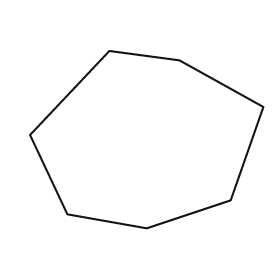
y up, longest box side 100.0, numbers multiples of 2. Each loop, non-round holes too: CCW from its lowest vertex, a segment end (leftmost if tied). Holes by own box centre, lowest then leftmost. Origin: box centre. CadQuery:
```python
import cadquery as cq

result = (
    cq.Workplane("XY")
    .moveTo(0.0, -38.0)
    .lineTo(36.0, -26.0)
    .lineTo(50.0, 14.0)
    .lineTo(14.0, 34.0)
    .lineTo(-16.0, 38.0)
    .lineTo(-50.0, 2.0)
    .lineTo(-34.0, -32.0)
    .close()
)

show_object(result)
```